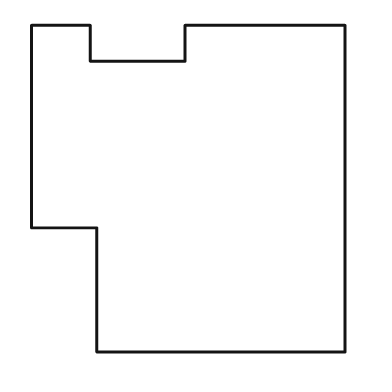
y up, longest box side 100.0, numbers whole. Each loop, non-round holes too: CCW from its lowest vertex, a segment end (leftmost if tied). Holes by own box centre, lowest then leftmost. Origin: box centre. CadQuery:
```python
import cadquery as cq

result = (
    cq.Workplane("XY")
    .moveTo(-28.0, -50.0)
    .lineTo(48.0, -50.0)
    .lineTo(48.0, 50.0)
    .lineTo(-1.0, 50.0)
    .lineTo(-1.0, 39.0)
    .lineTo(-30.0, 39.0)
    .lineTo(-30.0, 50.0)
    .lineTo(-48.0, 50.0)
    .lineTo(-48.0, -12.0)
    .lineTo(-28.0, -12.0)
    .close()
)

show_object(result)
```